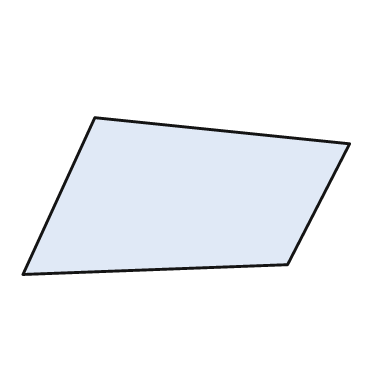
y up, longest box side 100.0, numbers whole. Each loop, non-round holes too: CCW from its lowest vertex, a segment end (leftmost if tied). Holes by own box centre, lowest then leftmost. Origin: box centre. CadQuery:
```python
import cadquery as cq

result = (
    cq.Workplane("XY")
    .moveTo(-50.0, -24.0)
    .lineTo(31.0, -21.0)
    .lineTo(50.0, 16.0)
    .lineTo(-28.0, 24.0)
    .close()
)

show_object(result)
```